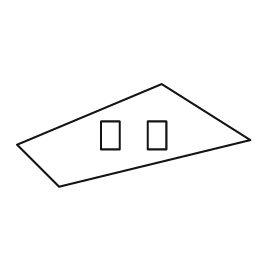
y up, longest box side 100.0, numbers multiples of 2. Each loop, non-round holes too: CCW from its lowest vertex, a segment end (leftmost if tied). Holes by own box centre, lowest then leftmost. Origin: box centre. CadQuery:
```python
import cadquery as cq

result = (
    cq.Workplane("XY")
    .moveTo(-32.0, -22.0)
    .lineTo(50.0, -2.0)
    .lineTo(12.0, 22.0)
    .lineTo(-50.0, -4.0)
    .close()
    .moveTo(-14.0, -6.0)
    .lineTo(-6.0, -6.0)
    .lineTo(-6.0, 6.0)
    .lineTo(-14.0, 6.0)
    .close()
    .moveTo(6.0, -6.0)
    .lineTo(14.0, -6.0)
    .lineTo(14.0, 6.0)
    .lineTo(6.0, 6.0)
    .close()
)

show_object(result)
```